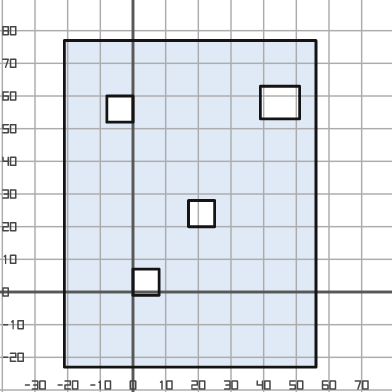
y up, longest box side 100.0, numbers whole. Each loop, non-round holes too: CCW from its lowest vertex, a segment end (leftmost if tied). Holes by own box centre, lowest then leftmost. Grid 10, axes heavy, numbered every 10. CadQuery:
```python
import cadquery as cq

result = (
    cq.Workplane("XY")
    .moveTo(-21.0, -23.0)
    .lineTo(56.0, -23.0)
    .lineTo(56.0, 77.0)
    .lineTo(-21.0, 77.0)
    .close()
    .moveTo(0.0, -1.0)
    .lineTo(8.0, -1.0)
    .lineTo(8.0, 7.0)
    .lineTo(0.0, 7.0)
    .close()
    .moveTo(17.0, 20.0)
    .lineTo(25.0, 20.0)
    .lineTo(25.0, 28.0)
    .lineTo(17.0, 28.0)
    .close()
    .moveTo(-8.0, 52.0)
    .lineTo(0.0, 52.0)
    .lineTo(0.0, 60.0)
    .lineTo(-8.0, 60.0)
    .close()
    .moveTo(39.0, 53.0)
    .lineTo(51.0, 53.0)
    .lineTo(51.0, 63.0)
    .lineTo(39.0, 63.0)
    .close()
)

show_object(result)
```